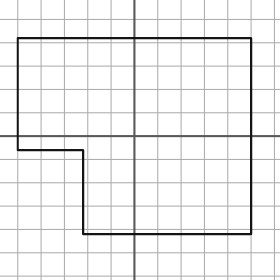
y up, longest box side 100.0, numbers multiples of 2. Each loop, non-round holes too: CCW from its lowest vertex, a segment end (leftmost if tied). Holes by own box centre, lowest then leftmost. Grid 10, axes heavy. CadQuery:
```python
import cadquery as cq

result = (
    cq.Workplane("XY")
    .moveTo(-22.0, -42.0)
    .lineTo(50.0, -42.0)
    .lineTo(50.0, 42.0)
    .lineTo(-50.0, 42.0)
    .lineTo(-50.0, -6.0)
    .lineTo(-22.0, -6.0)
    .close()
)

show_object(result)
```